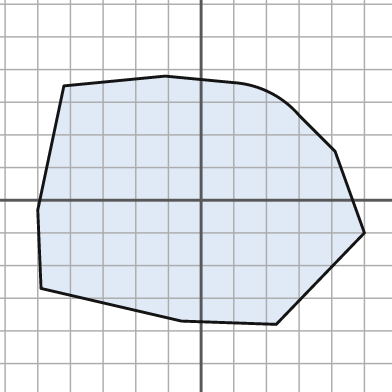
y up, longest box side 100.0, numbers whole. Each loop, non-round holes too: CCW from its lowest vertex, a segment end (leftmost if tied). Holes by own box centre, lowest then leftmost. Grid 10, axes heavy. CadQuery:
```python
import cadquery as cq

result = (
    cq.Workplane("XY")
    .moveTo(23.0, -38.0)
    .lineTo(50.0, -10.0)
    .lineTo(41.0, 15.0)
    .lineTo(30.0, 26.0)
    .threePointArc((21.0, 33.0), (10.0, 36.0))
    .lineTo(-11.0, 38.0)
    .lineTo(-42.0, 35.0)
    .lineTo(-50.0, -3.0)
    .lineTo(-49.0, -27.0)
    .lineTo(-6.0, -37.0)
    .close()
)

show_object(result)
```